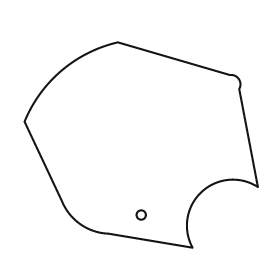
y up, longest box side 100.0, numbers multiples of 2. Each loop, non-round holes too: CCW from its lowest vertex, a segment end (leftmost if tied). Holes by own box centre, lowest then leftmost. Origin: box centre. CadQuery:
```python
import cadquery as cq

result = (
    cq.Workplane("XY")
    .moveTo(22.0, -44.0)
    .threePointArc((26.0, -20.0), (50.0, -18.0))
    .lineTo(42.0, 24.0)
    .threePointArc((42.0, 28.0), (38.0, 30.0))
    .lineTo(-10.0, 44.0)
    .threePointArc((-34.0, 32.0), (-50.0, 10.0))
    .lineTo(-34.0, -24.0)
    .threePointArc((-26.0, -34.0), (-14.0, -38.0))
    .close()
    .moveTo(0.0, -30.0)
    .circle(2.0)
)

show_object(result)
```